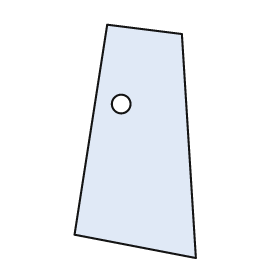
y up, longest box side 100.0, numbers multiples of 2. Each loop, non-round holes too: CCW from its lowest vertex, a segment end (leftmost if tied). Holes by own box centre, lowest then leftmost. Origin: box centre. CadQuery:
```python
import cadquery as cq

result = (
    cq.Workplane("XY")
    .moveTo(26.0, -50.0)
    .lineTo(20.0, 46.0)
    .lineTo(-12.0, 50.0)
    .lineTo(-26.0, -40.0)
    .close()
    .moveTo(-6.0, 16.0)
    .circle(4.0)
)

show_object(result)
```